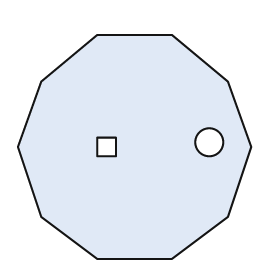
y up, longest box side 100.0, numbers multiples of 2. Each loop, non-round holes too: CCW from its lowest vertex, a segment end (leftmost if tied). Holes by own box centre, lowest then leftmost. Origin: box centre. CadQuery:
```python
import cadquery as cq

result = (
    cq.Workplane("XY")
    .moveTo(-16.0, -48.0)
    .lineTo(16.0, -48.0)
    .lineTo(40.0, -30.0)
    .lineTo(50.0, 0.0)
    .lineTo(40.0, 28.0)
    .lineTo(16.0, 48.0)
    .lineTo(-16.0, 48.0)
    .lineTo(-40.0, 28.0)
    .lineTo(-50.0, 0.0)
    .lineTo(-40.0, -30.0)
    .close()
    .moveTo(-16.0, -4.0)
    .lineTo(-8.0, -4.0)
    .lineTo(-8.0, 4.0)
    .lineTo(-16.0, 4.0)
    .close()
    .moveTo(32.0, 2.0)
    .circle(6.0)
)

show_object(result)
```